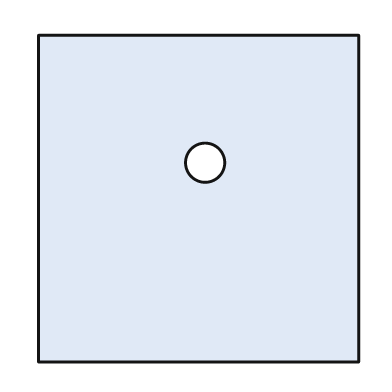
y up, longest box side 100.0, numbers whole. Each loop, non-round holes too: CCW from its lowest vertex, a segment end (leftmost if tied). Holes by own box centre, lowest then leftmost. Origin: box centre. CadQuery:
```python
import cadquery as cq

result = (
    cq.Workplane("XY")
    .moveTo(-49.0, -50.0)
    .lineTo(49.0, -50.0)
    .lineTo(49.0, 50.0)
    .lineTo(-49.0, 50.0)
    .close()
    .moveTo(2.0, 11.0)
    .circle(6.0)
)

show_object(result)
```